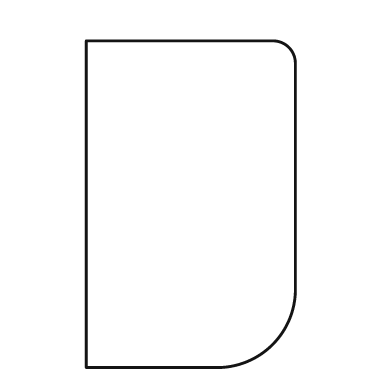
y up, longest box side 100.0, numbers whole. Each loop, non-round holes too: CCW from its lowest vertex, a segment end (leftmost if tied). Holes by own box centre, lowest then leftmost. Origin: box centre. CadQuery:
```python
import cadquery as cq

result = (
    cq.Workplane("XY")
    .moveTo(-32.0, -50.0)
    .lineTo(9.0, -50.0)
    .threePointArc((25.0, -43.0), (32.0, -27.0))
    .lineTo(32.0, 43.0)
    .threePointArc((30.0, 48.0), (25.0, 50.0))
    .lineTo(-32.0, 50.0)
    .close()
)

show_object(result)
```